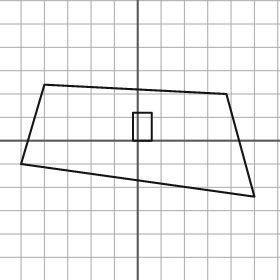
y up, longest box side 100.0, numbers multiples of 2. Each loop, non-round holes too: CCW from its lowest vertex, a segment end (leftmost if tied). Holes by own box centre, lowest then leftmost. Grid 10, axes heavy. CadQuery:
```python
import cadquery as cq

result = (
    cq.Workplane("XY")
    .moveTo(50.0, -24.0)
    .lineTo(38.0, 20.0)
    .lineTo(-40.0, 24.0)
    .lineTo(-50.0, -10.0)
    .close()
    .moveTo(-2.0, 0.0)
    .lineTo(6.0, 0.0)
    .lineTo(6.0, 12.0)
    .lineTo(-2.0, 12.0)
    .close()
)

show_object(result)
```